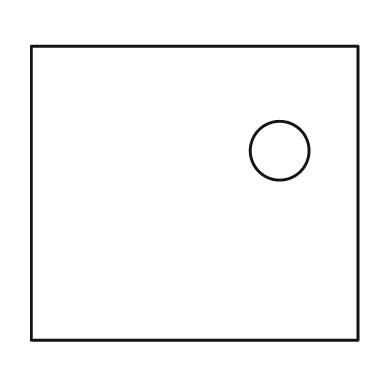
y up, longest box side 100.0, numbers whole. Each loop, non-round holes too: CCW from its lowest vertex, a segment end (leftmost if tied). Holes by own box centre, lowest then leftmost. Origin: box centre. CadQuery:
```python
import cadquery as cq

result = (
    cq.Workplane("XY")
    .moveTo(-50.0, -45.0)
    .lineTo(50.0, -45.0)
    .lineTo(50.0, 45.0)
    .lineTo(-50.0, 45.0)
    .close()
    .moveTo(26.0, 13.0)
    .circle(9.0)
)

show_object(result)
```